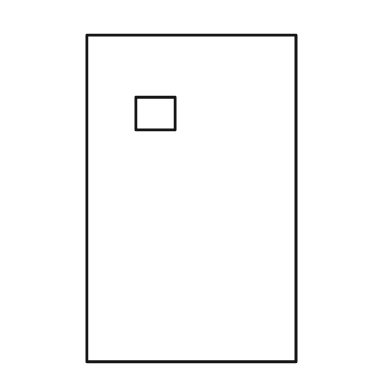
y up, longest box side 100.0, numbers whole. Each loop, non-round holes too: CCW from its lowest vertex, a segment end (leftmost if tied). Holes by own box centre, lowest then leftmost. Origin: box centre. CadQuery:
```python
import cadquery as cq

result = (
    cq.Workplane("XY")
    .moveTo(-32.0, -50.0)
    .lineTo(32.0, -50.0)
    .lineTo(32.0, 50.0)
    .lineTo(-32.0, 50.0)
    .close()
    .moveTo(-17.0, 21.0)
    .lineTo(-5.0, 21.0)
    .lineTo(-5.0, 31.0)
    .lineTo(-17.0, 31.0)
    .close()
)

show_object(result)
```